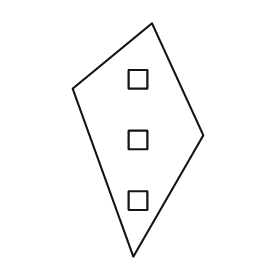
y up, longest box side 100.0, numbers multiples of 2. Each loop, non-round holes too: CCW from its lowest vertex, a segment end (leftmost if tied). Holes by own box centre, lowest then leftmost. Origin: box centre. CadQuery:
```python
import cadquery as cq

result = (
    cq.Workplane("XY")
    .moveTo(-2.0, -50.0)
    .lineTo(28.0, 2.0)
    .lineTo(6.0, 50.0)
    .lineTo(-28.0, 22.0)
    .close()
    .moveTo(-4.0, -30.0)
    .lineTo(4.0, -30.0)
    .lineTo(4.0, -22.0)
    .lineTo(-4.0, -22.0)
    .close()
    .moveTo(-4.0, -4.0)
    .lineTo(4.0, -4.0)
    .lineTo(4.0, 4.0)
    .lineTo(-4.0, 4.0)
    .close()
    .moveTo(-4.0, 22.0)
    .lineTo(4.0, 22.0)
    .lineTo(4.0, 30.0)
    .lineTo(-4.0, 30.0)
    .close()
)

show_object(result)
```